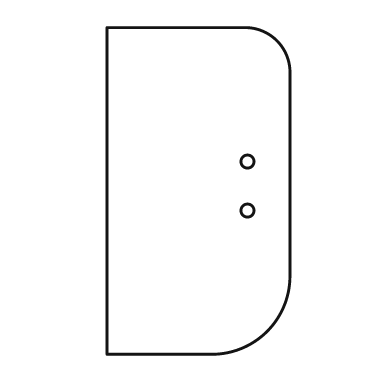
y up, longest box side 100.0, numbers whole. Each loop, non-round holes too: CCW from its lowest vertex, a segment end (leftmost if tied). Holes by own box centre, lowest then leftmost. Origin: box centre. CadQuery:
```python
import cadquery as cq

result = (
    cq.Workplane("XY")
    .moveTo(-28.0, -50.0)
    .lineTo(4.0, -50.0)
    .threePointArc((21.0, -43.0), (28.0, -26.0))
    .lineTo(28.0, 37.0)
    .threePointArc((24.0, 46.0), (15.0, 50.0))
    .lineTo(-28.0, 50.0)
    .close()
    .moveTo(15.0, -6.0)
    .circle(2.0)
    .moveTo(15.0, 9.0)
    .circle(2.0)
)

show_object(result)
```